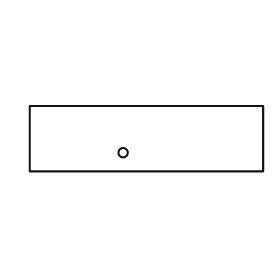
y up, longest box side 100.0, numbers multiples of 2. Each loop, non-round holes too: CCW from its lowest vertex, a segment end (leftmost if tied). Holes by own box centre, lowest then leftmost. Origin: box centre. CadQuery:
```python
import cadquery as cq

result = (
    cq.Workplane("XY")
    .moveTo(-50.0, -14.0)
    .lineTo(50.0, -14.0)
    .lineTo(50.0, 14.0)
    .lineTo(-50.0, 14.0)
    .close()
    .moveTo(-10.0, -6.0)
    .circle(2.0)
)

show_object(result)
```